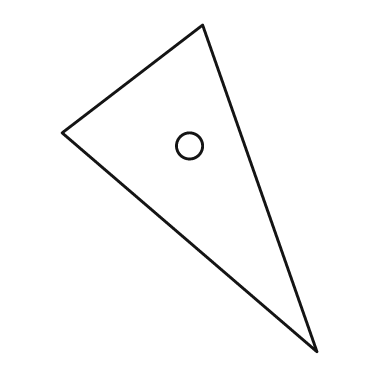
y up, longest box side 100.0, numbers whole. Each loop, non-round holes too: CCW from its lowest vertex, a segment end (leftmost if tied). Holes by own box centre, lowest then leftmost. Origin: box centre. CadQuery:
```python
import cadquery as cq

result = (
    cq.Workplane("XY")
    .moveTo(39.0, -50.0)
    .lineTo(4.0, 50.0)
    .lineTo(-39.0, 17.0)
    .close()
    .moveTo(0.0, 13.0)
    .circle(4.0)
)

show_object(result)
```